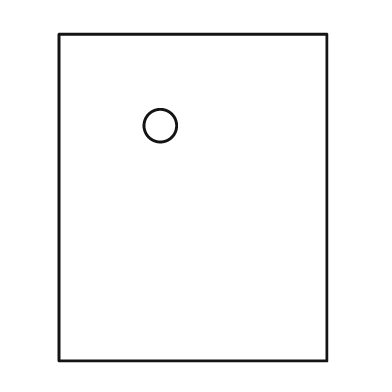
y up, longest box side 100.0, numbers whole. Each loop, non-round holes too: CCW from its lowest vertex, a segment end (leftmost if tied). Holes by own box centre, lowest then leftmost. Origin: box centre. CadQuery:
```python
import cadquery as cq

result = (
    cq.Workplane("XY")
    .moveTo(-41.0, -50.0)
    .lineTo(41.0, -50.0)
    .lineTo(41.0, 50.0)
    .lineTo(-41.0, 50.0)
    .close()
    .moveTo(-10.0, 22.0)
    .circle(5.0)
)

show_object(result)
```